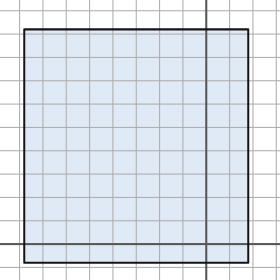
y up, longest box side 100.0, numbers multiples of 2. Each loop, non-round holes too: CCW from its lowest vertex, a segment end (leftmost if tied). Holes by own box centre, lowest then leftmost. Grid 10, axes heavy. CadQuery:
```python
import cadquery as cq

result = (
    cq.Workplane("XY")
    .moveTo(-78.0, -8.0)
    .lineTo(18.0, -8.0)
    .lineTo(18.0, 92.0)
    .lineTo(-78.0, 92.0)
    .close()
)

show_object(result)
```